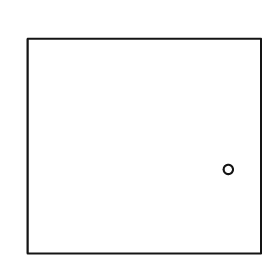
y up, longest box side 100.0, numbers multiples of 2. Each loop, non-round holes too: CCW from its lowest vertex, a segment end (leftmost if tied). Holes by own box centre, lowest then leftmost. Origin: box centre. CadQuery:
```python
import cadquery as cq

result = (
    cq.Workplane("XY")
    .moveTo(-50.0, -46.0)
    .lineTo(50.0, -46.0)
    .lineTo(50.0, 46.0)
    .lineTo(-50.0, 46.0)
    .close()
    .moveTo(36.0, -10.0)
    .circle(2.0)
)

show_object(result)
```